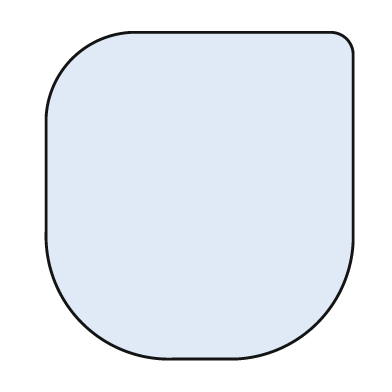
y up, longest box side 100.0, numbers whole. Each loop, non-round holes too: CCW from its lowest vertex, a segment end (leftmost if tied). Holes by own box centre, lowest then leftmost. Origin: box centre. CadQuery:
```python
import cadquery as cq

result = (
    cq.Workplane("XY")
    .moveTo(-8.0, -50.0)
    .lineTo(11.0, -50.0)
    .threePointArc((36.0, -39.0), (47.0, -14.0))
    .lineTo(47.0, 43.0)
    .threePointArc((45.0, 48.0), (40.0, 50.0))
    .lineTo(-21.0, 50.0)
    .threePointArc((-39.0, 42.0), (-47.0, 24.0))
    .lineTo(-47.0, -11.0)
    .threePointArc((-36.0, -39.0), (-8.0, -50.0))
    .close()
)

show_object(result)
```